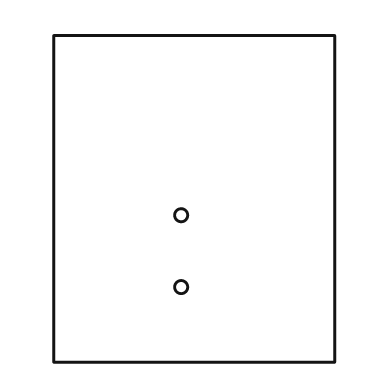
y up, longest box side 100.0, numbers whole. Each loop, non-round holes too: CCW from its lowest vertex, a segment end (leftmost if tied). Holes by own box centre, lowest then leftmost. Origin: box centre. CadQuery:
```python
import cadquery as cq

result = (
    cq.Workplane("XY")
    .moveTo(-43.0, -50.0)
    .lineTo(43.0, -50.0)
    .lineTo(43.0, 50.0)
    .lineTo(-43.0, 50.0)
    .close()
    .moveTo(-4.0, -27.0)
    .circle(2.0)
    .moveTo(-4.0, -5.0)
    .circle(2.0)
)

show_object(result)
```